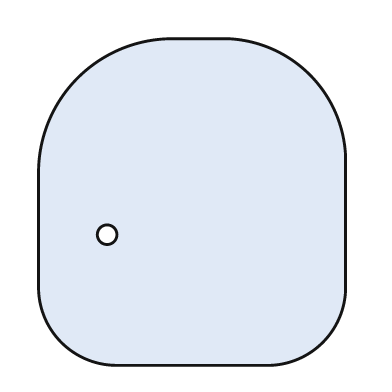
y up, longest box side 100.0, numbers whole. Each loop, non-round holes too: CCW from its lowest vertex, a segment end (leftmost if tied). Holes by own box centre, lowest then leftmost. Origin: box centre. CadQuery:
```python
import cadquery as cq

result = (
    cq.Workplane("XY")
    .moveTo(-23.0, -50.0)
    .lineTo(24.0, -50.0)
    .threePointArc((40.0, -43.0), (47.0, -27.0))
    .lineTo(47.0, 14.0)
    .threePointArc((36.0, 39.0), (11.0, 50.0))
    .lineTo(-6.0, 50.0)
    .threePointArc((-35.0, 38.0), (-47.0, 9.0))
    .lineTo(-47.0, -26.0)
    .threePointArc((-40.0, -43.0), (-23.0, -50.0))
    .close()
    .moveTo(-26.0, -10.0)
    .circle(3.0)
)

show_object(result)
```